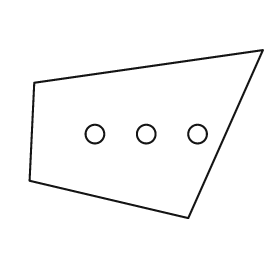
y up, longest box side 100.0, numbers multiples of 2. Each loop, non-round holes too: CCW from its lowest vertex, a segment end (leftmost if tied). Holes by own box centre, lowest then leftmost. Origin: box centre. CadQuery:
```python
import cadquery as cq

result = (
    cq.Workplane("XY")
    .moveTo(18.0, -36.0)
    .lineTo(50.0, 36.0)
    .lineTo(-48.0, 22.0)
    .lineTo(-50.0, -20.0)
    .close()
    .moveTo(-22.0, 0.0)
    .circle(4.0)
    .moveTo(0.0, 0.0)
    .circle(4.0)
    .moveTo(22.0, 0.0)
    .circle(4.0)
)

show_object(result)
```